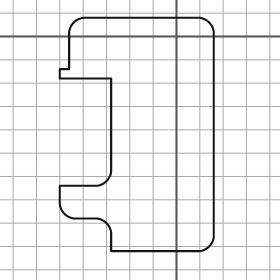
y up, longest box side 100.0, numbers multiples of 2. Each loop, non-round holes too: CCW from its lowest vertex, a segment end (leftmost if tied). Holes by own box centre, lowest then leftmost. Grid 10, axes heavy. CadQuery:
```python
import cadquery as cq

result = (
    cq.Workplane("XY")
    .moveTo(-28.0, -92.0)
    .lineTo(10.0, -92.0)
    .threePointArc((14.0, -90.0), (16.0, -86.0))
    .lineTo(16.0, 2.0)
    .threePointArc((14.0, 6.0), (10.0, 8.0))
    .lineTo(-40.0, 8.0)
    .threePointArc((-44.0, 6.0), (-46.0, 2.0))
    .lineTo(-46.0, -14.0)
    .lineTo(-50.0, -14.0)
    .lineTo(-50.0, -18.0)
    .lineTo(-28.0, -18.0)
    .lineTo(-28.0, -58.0)
    .threePointArc((-30.0, -62.0), (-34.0, -64.0))
    .lineTo(-50.0, -64.0)
    .lineTo(-50.0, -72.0)
    .threePointArc((-48.0, -76.0), (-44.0, -78.0))
    .lineTo(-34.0, -78.0)
    .threePointArc((-30.0, -80.0), (-28.0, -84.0))
    .close()
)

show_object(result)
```